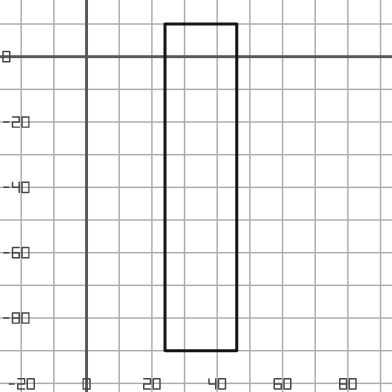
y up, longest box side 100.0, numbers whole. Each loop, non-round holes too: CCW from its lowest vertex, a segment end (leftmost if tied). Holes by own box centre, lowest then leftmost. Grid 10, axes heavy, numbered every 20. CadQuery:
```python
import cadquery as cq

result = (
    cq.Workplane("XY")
    .moveTo(24.0, -90.0)
    .lineTo(46.0, -90.0)
    .lineTo(46.0, 10.0)
    .lineTo(24.0, 10.0)
    .close()
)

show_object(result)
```